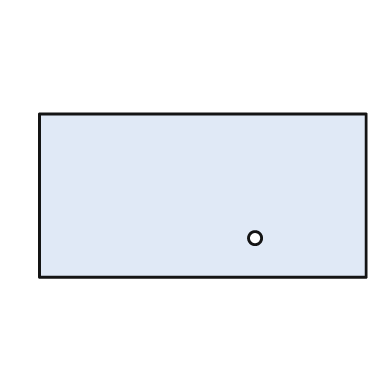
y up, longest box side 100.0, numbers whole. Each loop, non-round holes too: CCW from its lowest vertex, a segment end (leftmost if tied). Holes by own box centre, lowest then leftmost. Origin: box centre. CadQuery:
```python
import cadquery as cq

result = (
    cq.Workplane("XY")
    .moveTo(-50.0, -25.0)
    .lineTo(50.0, -25.0)
    .lineTo(50.0, 25.0)
    .lineTo(-50.0, 25.0)
    .close()
    .moveTo(16.0, -13.0)
    .circle(2.0)
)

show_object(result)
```